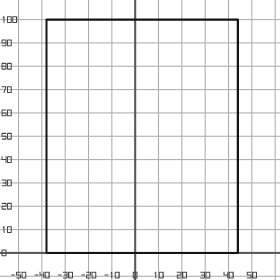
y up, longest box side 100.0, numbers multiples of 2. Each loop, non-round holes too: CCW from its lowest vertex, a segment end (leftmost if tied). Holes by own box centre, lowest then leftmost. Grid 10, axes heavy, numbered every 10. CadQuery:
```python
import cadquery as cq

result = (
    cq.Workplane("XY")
    .moveTo(-38.0, 0.0)
    .lineTo(44.0, 0.0)
    .lineTo(44.0, 100.0)
    .lineTo(-38.0, 100.0)
    .close()
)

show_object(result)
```